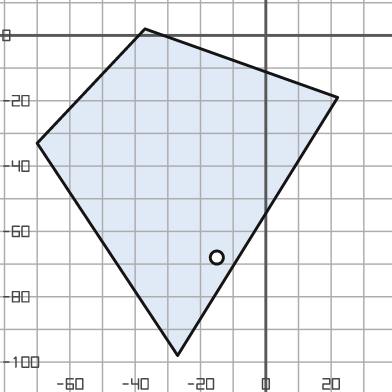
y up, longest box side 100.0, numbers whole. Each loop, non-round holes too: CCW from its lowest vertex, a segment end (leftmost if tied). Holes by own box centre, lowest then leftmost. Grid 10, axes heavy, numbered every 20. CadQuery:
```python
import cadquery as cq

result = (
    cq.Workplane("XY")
    .moveTo(-27.0, -98.0)
    .lineTo(22.0, -19.0)
    .lineTo(-37.0, 2.0)
    .lineTo(-70.0, -33.0)
    .close()
    .moveTo(-15.0, -68.0)
    .circle(2.0)
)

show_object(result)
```